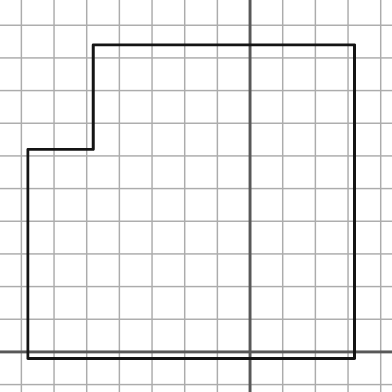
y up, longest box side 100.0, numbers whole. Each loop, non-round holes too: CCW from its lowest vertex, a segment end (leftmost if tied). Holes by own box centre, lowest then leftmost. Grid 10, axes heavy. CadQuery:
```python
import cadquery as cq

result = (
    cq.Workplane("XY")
    .moveTo(-68.0, -2.0)
    .lineTo(32.0, -2.0)
    .lineTo(32.0, 94.0)
    .lineTo(-48.0, 94.0)
    .lineTo(-48.0, 62.0)
    .lineTo(-68.0, 62.0)
    .close()
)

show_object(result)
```